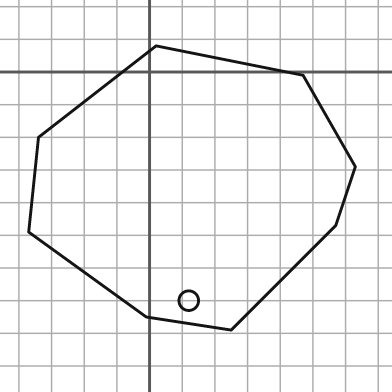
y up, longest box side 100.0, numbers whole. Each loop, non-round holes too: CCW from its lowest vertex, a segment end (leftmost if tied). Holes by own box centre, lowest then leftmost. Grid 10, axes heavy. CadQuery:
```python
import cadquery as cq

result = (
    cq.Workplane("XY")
    .moveTo(25.0, -79.0)
    .lineTo(57.0, -47.0)
    .lineTo(63.0, -29.0)
    .lineTo(47.0, -1.0)
    .lineTo(2.0, 8.0)
    .lineTo(-34.0, -20.0)
    .lineTo(-37.0, -49.0)
    .lineTo(-1.0, -75.0)
    .close()
    .moveTo(12.0, -70.0)
    .circle(3.0)
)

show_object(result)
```